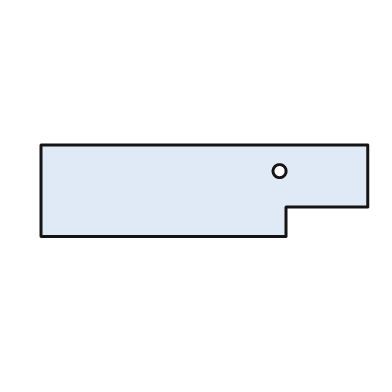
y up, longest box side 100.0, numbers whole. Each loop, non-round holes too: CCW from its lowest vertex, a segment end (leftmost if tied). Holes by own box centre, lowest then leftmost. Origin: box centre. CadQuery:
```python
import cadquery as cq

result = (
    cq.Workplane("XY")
    .moveTo(-50.0, -14.0)
    .lineTo(25.0, -14.0)
    .lineTo(25.0, -5.0)
    .lineTo(50.0, -5.0)
    .lineTo(50.0, 14.0)
    .lineTo(-50.0, 14.0)
    .close()
    .moveTo(23.0, 6.0)
    .circle(2.0)
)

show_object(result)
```